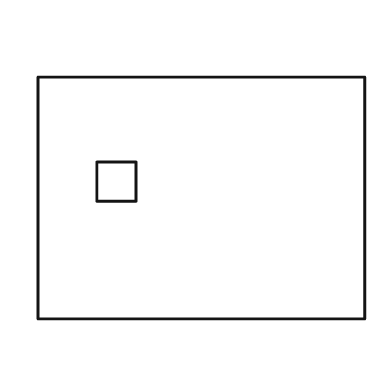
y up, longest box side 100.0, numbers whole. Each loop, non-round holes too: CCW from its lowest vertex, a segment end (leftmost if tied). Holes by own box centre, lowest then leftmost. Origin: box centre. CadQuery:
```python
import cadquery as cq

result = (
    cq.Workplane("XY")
    .moveTo(-50.0, -37.0)
    .lineTo(50.0, -37.0)
    .lineTo(50.0, 37.0)
    .lineTo(-50.0, 37.0)
    .close()
    .moveTo(-32.0, -1.0)
    .lineTo(-20.0, -1.0)
    .lineTo(-20.0, 11.0)
    .lineTo(-32.0, 11.0)
    .close()
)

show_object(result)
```